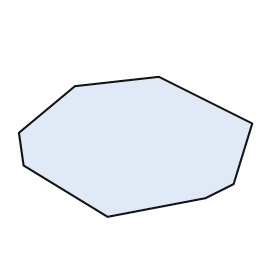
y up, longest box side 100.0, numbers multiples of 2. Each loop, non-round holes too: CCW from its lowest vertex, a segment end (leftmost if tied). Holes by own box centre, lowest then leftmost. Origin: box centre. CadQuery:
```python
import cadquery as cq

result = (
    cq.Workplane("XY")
    .moveTo(-12.0, -30.0)
    .lineTo(30.0, -22.0)
    .lineTo(42.0, -16.0)
    .lineTo(50.0, 10.0)
    .lineTo(10.0, 30.0)
    .lineTo(-26.0, 26.0)
    .lineTo(-50.0, 6.0)
    .lineTo(-48.0, -8.0)
    .close()
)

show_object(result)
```